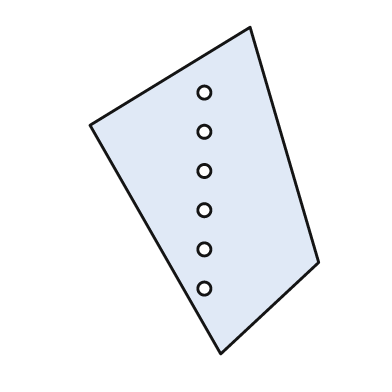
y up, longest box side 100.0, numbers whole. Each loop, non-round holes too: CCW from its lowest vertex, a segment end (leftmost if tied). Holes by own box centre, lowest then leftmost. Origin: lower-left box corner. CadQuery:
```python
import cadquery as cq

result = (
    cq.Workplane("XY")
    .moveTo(40.0, 0.0)
    .lineTo(70.0, 28.0)
    .lineTo(49.0, 100.0)
    .lineTo(0.0, 70.0)
    .close()
    .moveTo(35.0, 20.0)
    .circle(2.0)
    .moveTo(35.0, 32.0)
    .circle(2.0)
    .moveTo(35.0, 44.0)
    .circle(2.0)
    .moveTo(35.0, 56.0)
    .circle(2.0)
    .moveTo(35.0, 68.0)
    .circle(2.0)
    .moveTo(35.0, 80.0)
    .circle(2.0)
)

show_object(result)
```